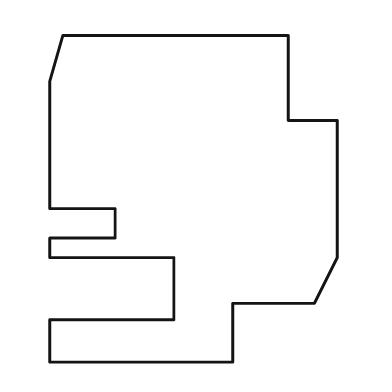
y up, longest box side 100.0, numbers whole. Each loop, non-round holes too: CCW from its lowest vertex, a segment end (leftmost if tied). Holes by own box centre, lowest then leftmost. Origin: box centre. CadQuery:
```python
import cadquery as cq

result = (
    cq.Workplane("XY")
    .moveTo(-44.0, -50.0)
    .lineTo(12.0, -50.0)
    .lineTo(12.0, -32.0)
    .lineTo(37.0, -32.0)
    .lineTo(44.0, -18.0)
    .lineTo(44.0, 24.0)
    .lineTo(29.0, 24.0)
    .lineTo(29.0, 50.0)
    .lineTo(-40.0, 50.0)
    .lineTo(-44.0, 36.0)
    .lineTo(-44.0, -3.0)
    .lineTo(-24.0, -3.0)
    .lineTo(-24.0, -12.0)
    .lineTo(-44.0, -12.0)
    .lineTo(-44.0, -18.0)
    .lineTo(-6.0, -18.0)
    .lineTo(-6.0, -37.0)
    .lineTo(-44.0, -37.0)
    .close()
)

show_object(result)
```